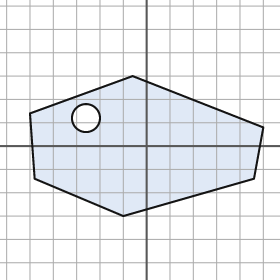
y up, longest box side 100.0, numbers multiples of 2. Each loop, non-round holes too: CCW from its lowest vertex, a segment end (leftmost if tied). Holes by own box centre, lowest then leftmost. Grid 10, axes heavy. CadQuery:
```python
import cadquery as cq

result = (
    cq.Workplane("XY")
    .moveTo(-10.0, -30.0)
    .lineTo(46.0, -14.0)
    .lineTo(50.0, 8.0)
    .lineTo(-6.0, 30.0)
    .lineTo(-50.0, 14.0)
    .lineTo(-48.0, -14.0)
    .close()
    .moveTo(-26.0, 12.0)
    .circle(6.0)
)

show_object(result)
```